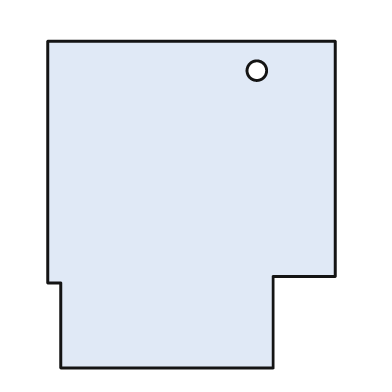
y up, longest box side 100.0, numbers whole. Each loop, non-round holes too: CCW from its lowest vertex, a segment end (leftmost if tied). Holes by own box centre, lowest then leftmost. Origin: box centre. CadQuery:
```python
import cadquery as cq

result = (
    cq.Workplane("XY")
    .moveTo(-40.0, -50.0)
    .lineTo(25.0, -50.0)
    .lineTo(25.0, -22.0)
    .lineTo(44.0, -22.0)
    .lineTo(44.0, 50.0)
    .lineTo(-44.0, 50.0)
    .lineTo(-44.0, -24.0)
    .lineTo(-40.0, -24.0)
    .close()
    .moveTo(20.0, 41.0)
    .circle(3.0)
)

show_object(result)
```